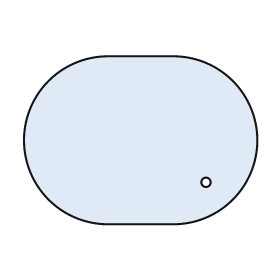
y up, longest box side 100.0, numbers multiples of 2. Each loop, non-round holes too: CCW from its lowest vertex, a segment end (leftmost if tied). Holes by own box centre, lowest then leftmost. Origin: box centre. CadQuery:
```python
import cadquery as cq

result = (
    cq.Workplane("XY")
    .moveTo(-14.0, -36.0)
    .lineTo(14.0, -36.0)
    .threePointArc((50.0, 0.0), (14.0, 36.0))
    .lineTo(-14.0, 36.0)
    .threePointArc((-50.0, 0.0), (-14.0, -36.0))
    .close()
    .moveTo(28.0, -18.0)
    .circle(2.0)
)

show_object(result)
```